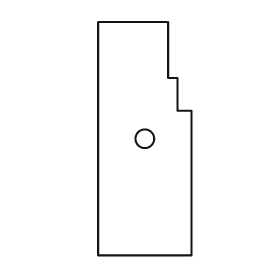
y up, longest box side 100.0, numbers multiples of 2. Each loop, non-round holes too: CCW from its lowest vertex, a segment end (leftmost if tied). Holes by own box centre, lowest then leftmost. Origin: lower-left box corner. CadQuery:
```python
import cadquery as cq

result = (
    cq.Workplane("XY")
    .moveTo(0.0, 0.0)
    .lineTo(40.0, 0.0)
    .lineTo(40.0, 62.0)
    .lineTo(34.0, 62.0)
    .lineTo(34.0, 76.0)
    .lineTo(30.0, 76.0)
    .lineTo(30.0, 100.0)
    .lineTo(0.0, 100.0)
    .close()
    .moveTo(20.0, 50.0)
    .circle(4.0)
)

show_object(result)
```